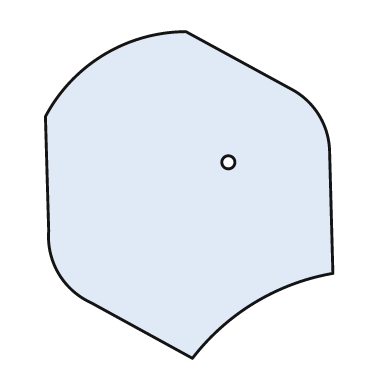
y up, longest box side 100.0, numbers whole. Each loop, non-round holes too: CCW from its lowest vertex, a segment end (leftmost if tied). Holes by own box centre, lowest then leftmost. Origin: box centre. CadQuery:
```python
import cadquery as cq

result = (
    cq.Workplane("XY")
    .moveTo(1.0, -50.0)
    .threePointArc((20.0, -33.0), (44.0, -24.0))
    .lineTo(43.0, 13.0)
    .threePointArc((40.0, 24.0), (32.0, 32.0))
    .lineTo(-1.0, 50.0)
    .threePointArc((-26.0, 43.0), (-44.0, 24.0))
    .lineTo(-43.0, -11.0)
    .threePointArc((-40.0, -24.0), (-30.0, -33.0))
    .close()
    .moveTo(12.0, 10.0)
    .circle(2.0)
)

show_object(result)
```